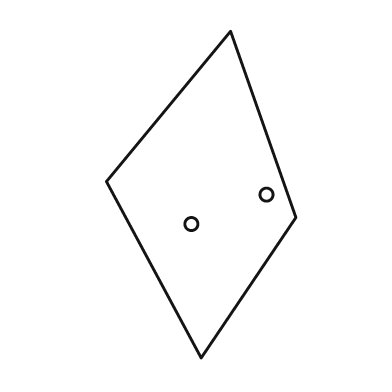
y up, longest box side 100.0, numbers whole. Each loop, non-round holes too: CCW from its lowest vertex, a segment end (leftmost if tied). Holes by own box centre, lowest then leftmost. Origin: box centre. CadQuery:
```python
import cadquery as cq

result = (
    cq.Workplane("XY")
    .moveTo(0.0, -50.0)
    .lineTo(29.0, -7.0)
    .lineTo(9.0, 50.0)
    .lineTo(-29.0, 4.0)
    .close()
    .moveTo(-3.0, -9.0)
    .circle(2.0)
    .moveTo(20.0, 0.0)
    .circle(2.0)
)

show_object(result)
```